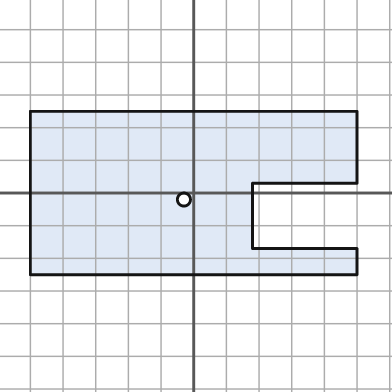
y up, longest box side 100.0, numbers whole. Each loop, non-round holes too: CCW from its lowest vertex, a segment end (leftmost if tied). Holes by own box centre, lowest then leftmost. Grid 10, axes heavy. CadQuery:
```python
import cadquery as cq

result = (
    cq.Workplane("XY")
    .moveTo(-50.0, -25.0)
    .lineTo(50.0, -25.0)
    .lineTo(50.0, -17.0)
    .lineTo(18.0, -17.0)
    .lineTo(18.0, 3.0)
    .lineTo(50.0, 3.0)
    .lineTo(50.0, 25.0)
    .lineTo(-50.0, 25.0)
    .close()
    .moveTo(-3.0, -2.0)
    .circle(2.0)
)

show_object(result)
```